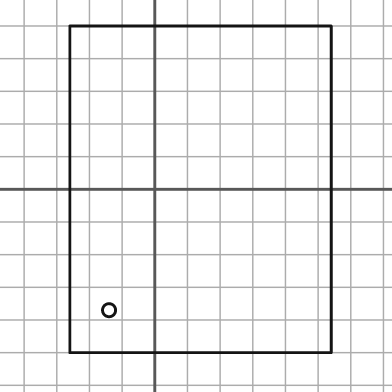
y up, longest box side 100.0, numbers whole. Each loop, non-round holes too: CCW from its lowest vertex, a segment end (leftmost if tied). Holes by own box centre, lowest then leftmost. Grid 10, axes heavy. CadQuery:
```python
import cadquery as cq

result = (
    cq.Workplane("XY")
    .moveTo(-26.0, -50.0)
    .lineTo(54.0, -50.0)
    .lineTo(54.0, 50.0)
    .lineTo(-26.0, 50.0)
    .close()
    .moveTo(-14.0, -37.0)
    .circle(2.0)
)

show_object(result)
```